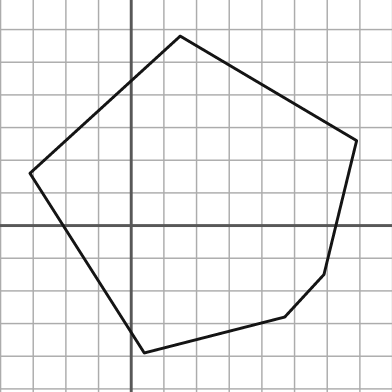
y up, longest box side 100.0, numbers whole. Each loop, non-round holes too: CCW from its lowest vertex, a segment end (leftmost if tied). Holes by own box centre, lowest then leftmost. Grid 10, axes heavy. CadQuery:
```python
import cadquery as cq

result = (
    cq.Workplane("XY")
    .moveTo(4.0, -39.0)
    .lineTo(47.0, -28.0)
    .lineTo(59.0, -15.0)
    .lineTo(69.0, 26.0)
    .lineTo(15.0, 58.0)
    .lineTo(-31.0, 16.0)
    .close()
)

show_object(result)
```